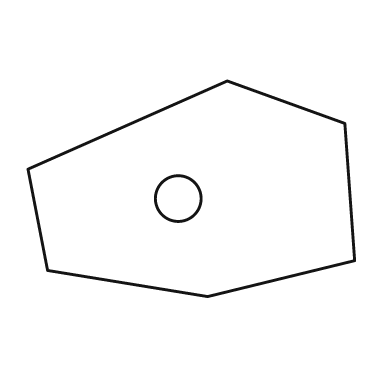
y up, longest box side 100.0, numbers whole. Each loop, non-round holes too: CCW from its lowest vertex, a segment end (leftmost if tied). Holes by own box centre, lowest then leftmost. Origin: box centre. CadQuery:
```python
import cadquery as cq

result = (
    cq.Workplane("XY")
    .moveTo(5.0, -33.0)
    .lineTo(50.0, -22.0)
    .lineTo(47.0, 20.0)
    .lineTo(11.0, 33.0)
    .lineTo(-50.0, 6.0)
    .lineTo(-44.0, -25.0)
    .close()
    .moveTo(-4.0, -3.0)
    .circle(7.0)
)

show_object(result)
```